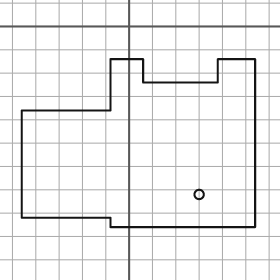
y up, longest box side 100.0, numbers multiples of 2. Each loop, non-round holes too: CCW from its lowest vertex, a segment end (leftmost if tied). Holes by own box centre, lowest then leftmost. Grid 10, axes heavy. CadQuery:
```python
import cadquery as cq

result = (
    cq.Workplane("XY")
    .moveTo(-8.0, -86.0)
    .lineTo(54.0, -86.0)
    .lineTo(54.0, -14.0)
    .lineTo(38.0, -14.0)
    .lineTo(38.0, -24.0)
    .lineTo(6.0, -24.0)
    .lineTo(6.0, -14.0)
    .lineTo(-8.0, -14.0)
    .lineTo(-8.0, -36.0)
    .lineTo(-46.0, -36.0)
    .lineTo(-46.0, -82.0)
    .lineTo(-8.0, -82.0)
    .close()
    .moveTo(30.0, -72.0)
    .circle(2.0)
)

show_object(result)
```